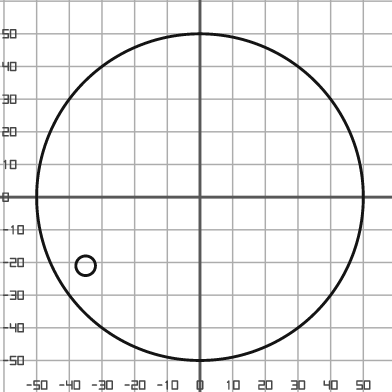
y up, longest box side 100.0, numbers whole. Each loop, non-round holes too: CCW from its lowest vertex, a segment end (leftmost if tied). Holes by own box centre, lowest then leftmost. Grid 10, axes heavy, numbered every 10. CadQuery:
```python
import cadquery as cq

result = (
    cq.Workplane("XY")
    .moveTo(0.0, 0.0)
    .circle(50.0)
    .moveTo(-35.0, -21.0)
    .circle(3.0)
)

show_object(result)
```